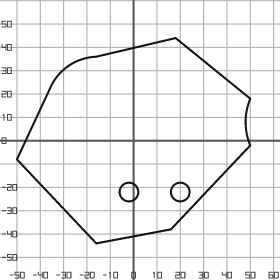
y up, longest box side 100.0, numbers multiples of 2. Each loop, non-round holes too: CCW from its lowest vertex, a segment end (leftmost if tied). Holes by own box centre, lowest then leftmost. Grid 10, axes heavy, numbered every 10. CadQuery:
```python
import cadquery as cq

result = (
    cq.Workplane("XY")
    .moveTo(-16.0, -44.0)
    .lineTo(16.0, -38.0)
    .lineTo(50.0, -2.0)
    .threePointArc((48.0, 8.0), (50.0, 18.0))
    .lineTo(18.0, 44.0)
    .lineTo(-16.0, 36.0)
    .threePointArc((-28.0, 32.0), (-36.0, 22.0))
    .lineTo(-50.0, -8.0)
    .close()
    .moveTo(-2.0, -22.0)
    .circle(4.0)
    .moveTo(20.0, -22.0)
    .circle(4.0)
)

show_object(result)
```